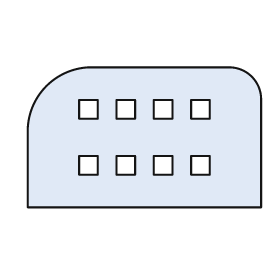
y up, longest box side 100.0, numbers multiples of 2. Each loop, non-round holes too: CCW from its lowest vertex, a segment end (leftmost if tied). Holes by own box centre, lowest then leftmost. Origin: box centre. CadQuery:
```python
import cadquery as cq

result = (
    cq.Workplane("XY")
    .moveTo(-50.0, -30.0)
    .lineTo(50.0, -30.0)
    .lineTo(50.0, 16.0)
    .threePointArc((46.0, 26.0), (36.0, 30.0))
    .lineTo(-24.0, 30.0)
    .threePointArc((-42.0, 22.0), (-50.0, 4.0))
    .close()
    .moveTo(-28.0, -16.0)
    .lineTo(-20.0, -16.0)
    .lineTo(-20.0, -8.0)
    .lineTo(-28.0, -8.0)
    .close()
    .moveTo(-12.0, -16.0)
    .lineTo(-4.0, -16.0)
    .lineTo(-4.0, -8.0)
    .lineTo(-12.0, -8.0)
    .close()
    .moveTo(4.0, -16.0)
    .lineTo(12.0, -16.0)
    .lineTo(12.0, -8.0)
    .lineTo(4.0, -8.0)
    .close()
    .moveTo(20.0, -16.0)
    .lineTo(28.0, -16.0)
    .lineTo(28.0, -8.0)
    .lineTo(20.0, -8.0)
    .close()
    .moveTo(-28.0, 8.0)
    .lineTo(-20.0, 8.0)
    .lineTo(-20.0, 16.0)
    .lineTo(-28.0, 16.0)
    .close()
    .moveTo(-12.0, 8.0)
    .lineTo(-4.0, 8.0)
    .lineTo(-4.0, 16.0)
    .lineTo(-12.0, 16.0)
    .close()
    .moveTo(4.0, 8.0)
    .lineTo(12.0, 8.0)
    .lineTo(12.0, 16.0)
    .lineTo(4.0, 16.0)
    .close()
    .moveTo(20.0, 8.0)
    .lineTo(28.0, 8.0)
    .lineTo(28.0, 16.0)
    .lineTo(20.0, 16.0)
    .close()
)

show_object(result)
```